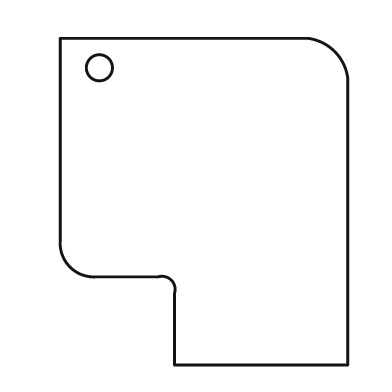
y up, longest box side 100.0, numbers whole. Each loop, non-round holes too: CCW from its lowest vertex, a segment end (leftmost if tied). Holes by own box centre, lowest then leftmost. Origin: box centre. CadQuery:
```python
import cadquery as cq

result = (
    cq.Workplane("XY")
    .moveTo(-9.0, -50.0)
    .lineTo(44.0, -50.0)
    .lineTo(44.0, 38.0)
    .threePointArc((40.0, 46.0), (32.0, 50.0))
    .lineTo(-44.0, 50.0)
    .lineTo(-44.0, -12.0)
    .threePointArc((-41.0, -20.0), (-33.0, -23.0))
    .lineTo(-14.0, -23.0)
    .threePointArc((-10.0, -24.0), (-9.0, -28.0))
    .close()
    .moveTo(-32.0, 41.0)
    .circle(4.0)
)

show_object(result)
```